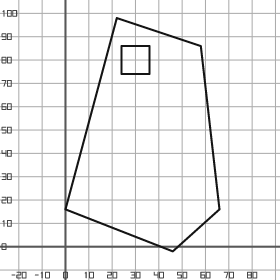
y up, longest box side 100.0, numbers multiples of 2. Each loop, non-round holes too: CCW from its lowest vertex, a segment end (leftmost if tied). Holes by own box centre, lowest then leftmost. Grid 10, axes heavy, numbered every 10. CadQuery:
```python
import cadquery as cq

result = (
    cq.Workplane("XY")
    .moveTo(46.0, -2.0)
    .lineTo(66.0, 16.0)
    .lineTo(58.0, 86.0)
    .lineTo(22.0, 98.0)
    .lineTo(0.0, 16.0)
    .close()
    .moveTo(24.0, 74.0)
    .lineTo(36.0, 74.0)
    .lineTo(36.0, 86.0)
    .lineTo(24.0, 86.0)
    .close()
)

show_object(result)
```